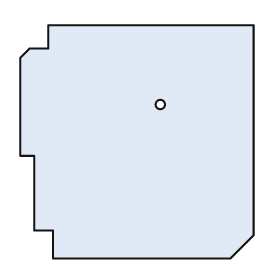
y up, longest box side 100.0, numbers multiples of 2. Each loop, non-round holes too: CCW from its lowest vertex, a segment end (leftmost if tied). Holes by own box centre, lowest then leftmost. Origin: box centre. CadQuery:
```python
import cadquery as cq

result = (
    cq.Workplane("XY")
    .moveTo(-36.0, -50.0)
    .lineTo(40.0, -50.0)
    .lineTo(50.0, -40.0)
    .lineTo(50.0, 50.0)
    .lineTo(-38.0, 50.0)
    .lineTo(-38.0, 40.0)
    .lineTo(-46.0, 40.0)
    .lineTo(-50.0, 36.0)
    .lineTo(-50.0, -6.0)
    .lineTo(-44.0, -6.0)
    .lineTo(-44.0, -38.0)
    .lineTo(-36.0, -38.0)
    .close()
    .moveTo(10.0, 16.0)
    .circle(2.0)
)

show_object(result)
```